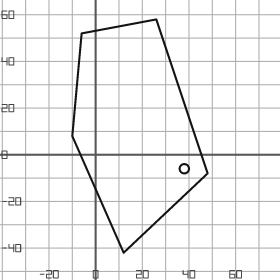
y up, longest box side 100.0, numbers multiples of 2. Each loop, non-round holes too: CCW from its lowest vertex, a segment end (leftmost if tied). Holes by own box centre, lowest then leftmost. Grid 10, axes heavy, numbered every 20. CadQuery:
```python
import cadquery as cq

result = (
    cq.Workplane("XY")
    .moveTo(12.0, -42.0)
    .lineTo(48.0, -8.0)
    .lineTo(26.0, 58.0)
    .lineTo(-6.0, 52.0)
    .lineTo(-10.0, 8.0)
    .close()
    .moveTo(38.0, -6.0)
    .circle(2.0)
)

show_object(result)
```